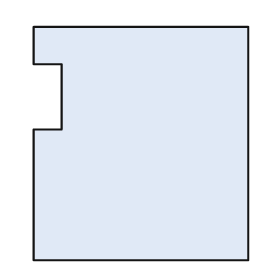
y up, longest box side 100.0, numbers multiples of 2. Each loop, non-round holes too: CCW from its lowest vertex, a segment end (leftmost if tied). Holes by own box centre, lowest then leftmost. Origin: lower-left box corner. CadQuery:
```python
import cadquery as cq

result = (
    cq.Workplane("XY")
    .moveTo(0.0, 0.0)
    .lineTo(92.0, 0.0)
    .lineTo(92.0, 100.0)
    .lineTo(0.0, 100.0)
    .lineTo(0.0, 84.0)
    .lineTo(12.0, 84.0)
    .lineTo(12.0, 56.0)
    .lineTo(0.0, 56.0)
    .close()
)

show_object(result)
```